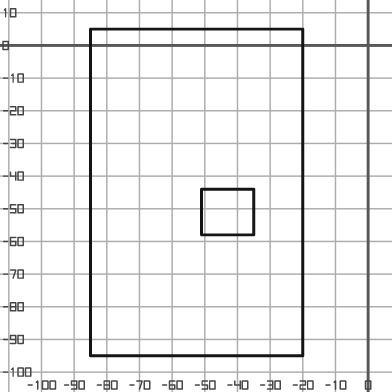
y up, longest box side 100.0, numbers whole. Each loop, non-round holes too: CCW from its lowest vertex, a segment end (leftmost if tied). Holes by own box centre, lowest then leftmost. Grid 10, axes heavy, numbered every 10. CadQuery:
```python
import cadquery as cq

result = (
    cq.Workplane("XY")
    .moveTo(-85.0, -95.0)
    .lineTo(-20.0, -95.0)
    .lineTo(-20.0, 5.0)
    .lineTo(-85.0, 5.0)
    .close()
    .moveTo(-51.0, -58.0)
    .lineTo(-35.0, -58.0)
    .lineTo(-35.0, -44.0)
    .lineTo(-51.0, -44.0)
    .close()
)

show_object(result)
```